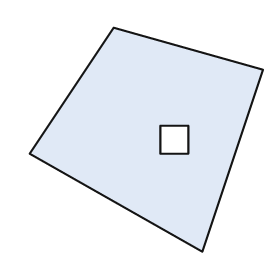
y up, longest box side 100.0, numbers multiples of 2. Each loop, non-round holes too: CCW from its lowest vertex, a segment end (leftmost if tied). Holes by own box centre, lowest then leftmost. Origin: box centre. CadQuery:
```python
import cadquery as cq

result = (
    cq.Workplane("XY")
    .moveTo(24.0, -48.0)
    .lineTo(50.0, 30.0)
    .lineTo(-14.0, 48.0)
    .lineTo(-50.0, -6.0)
    .close()
    .moveTo(6.0, -6.0)
    .lineTo(18.0, -6.0)
    .lineTo(18.0, 6.0)
    .lineTo(6.0, 6.0)
    .close()
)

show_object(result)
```